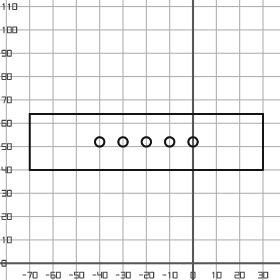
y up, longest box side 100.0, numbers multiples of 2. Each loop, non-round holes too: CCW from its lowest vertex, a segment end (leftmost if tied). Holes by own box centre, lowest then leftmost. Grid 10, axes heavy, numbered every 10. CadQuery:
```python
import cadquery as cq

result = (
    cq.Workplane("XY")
    .moveTo(-70.0, 40.0)
    .lineTo(30.0, 40.0)
    .lineTo(30.0, 64.0)
    .lineTo(-70.0, 64.0)
    .close()
    .moveTo(-40.0, 52.0)
    .circle(2.0)
    .moveTo(-30.0, 52.0)
    .circle(2.0)
    .moveTo(-20.0, 52.0)
    .circle(2.0)
    .moveTo(-10.0, 52.0)
    .circle(2.0)
    .moveTo(0.0, 52.0)
    .circle(2.0)
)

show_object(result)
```